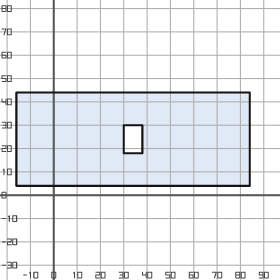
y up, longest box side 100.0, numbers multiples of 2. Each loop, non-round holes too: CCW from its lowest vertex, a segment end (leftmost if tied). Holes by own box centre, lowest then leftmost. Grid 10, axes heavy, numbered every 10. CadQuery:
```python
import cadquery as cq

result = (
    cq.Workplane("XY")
    .moveTo(-16.0, 4.0)
    .lineTo(84.0, 4.0)
    .lineTo(84.0, 44.0)
    .lineTo(-16.0, 44.0)
    .close()
    .moveTo(30.0, 18.0)
    .lineTo(38.0, 18.0)
    .lineTo(38.0, 30.0)
    .lineTo(30.0, 30.0)
    .close()
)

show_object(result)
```